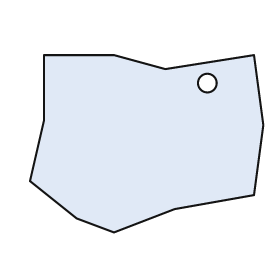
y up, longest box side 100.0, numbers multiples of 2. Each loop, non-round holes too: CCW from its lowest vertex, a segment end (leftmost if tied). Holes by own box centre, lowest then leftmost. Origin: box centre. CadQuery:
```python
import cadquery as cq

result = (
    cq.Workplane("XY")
    .moveTo(-14.0, -38.0)
    .lineTo(12.0, -28.0)
    .lineTo(46.0, -22.0)
    .lineTo(50.0, 8.0)
    .lineTo(46.0, 38.0)
    .lineTo(8.0, 32.0)
    .lineTo(-14.0, 38.0)
    .lineTo(-44.0, 38.0)
    .lineTo(-44.0, 10.0)
    .lineTo(-50.0, -16.0)
    .lineTo(-30.0, -32.0)
    .close()
    .moveTo(26.0, 26.0)
    .circle(4.0)
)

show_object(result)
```